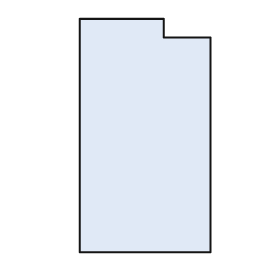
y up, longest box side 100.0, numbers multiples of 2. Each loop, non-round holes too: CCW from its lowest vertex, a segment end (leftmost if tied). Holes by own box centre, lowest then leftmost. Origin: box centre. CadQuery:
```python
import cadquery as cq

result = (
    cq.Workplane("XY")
    .moveTo(-28.0, -50.0)
    .lineTo(28.0, -50.0)
    .lineTo(28.0, 42.0)
    .lineTo(8.0, 42.0)
    .lineTo(8.0, 50.0)
    .lineTo(-28.0, 50.0)
    .close()
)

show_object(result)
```